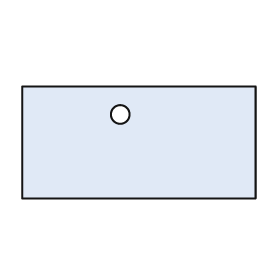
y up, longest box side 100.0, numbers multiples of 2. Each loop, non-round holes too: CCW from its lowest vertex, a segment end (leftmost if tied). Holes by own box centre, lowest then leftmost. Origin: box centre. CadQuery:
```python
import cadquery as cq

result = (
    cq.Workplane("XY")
    .moveTo(-50.0, -24.0)
    .lineTo(50.0, -24.0)
    .lineTo(50.0, 24.0)
    .lineTo(-50.0, 24.0)
    .close()
    .moveTo(-8.0, 12.0)
    .circle(4.0)
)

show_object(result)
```